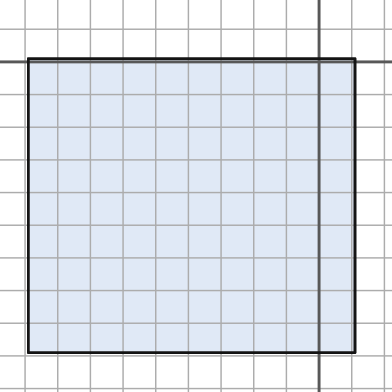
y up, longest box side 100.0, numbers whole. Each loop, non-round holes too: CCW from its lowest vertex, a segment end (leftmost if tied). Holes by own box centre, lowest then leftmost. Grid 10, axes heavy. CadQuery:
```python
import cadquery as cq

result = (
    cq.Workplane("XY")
    .moveTo(-89.0, -89.0)
    .lineTo(11.0, -89.0)
    .lineTo(11.0, 1.0)
    .lineTo(-89.0, 1.0)
    .close()
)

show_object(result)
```